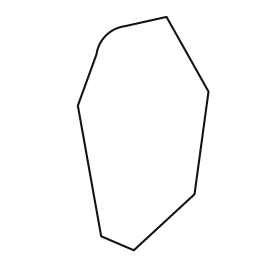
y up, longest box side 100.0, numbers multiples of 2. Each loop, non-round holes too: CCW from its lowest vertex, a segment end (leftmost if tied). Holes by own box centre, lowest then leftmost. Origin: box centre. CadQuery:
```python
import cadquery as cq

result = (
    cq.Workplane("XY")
    .moveTo(-4.0, -50.0)
    .lineTo(22.0, -26.0)
    .lineTo(28.0, 18.0)
    .lineTo(10.0, 50.0)
    .lineTo(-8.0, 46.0)
    .threePointArc((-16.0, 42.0), (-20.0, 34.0))
    .lineTo(-28.0, 12.0)
    .lineTo(-18.0, -44.0)
    .close()
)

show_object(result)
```